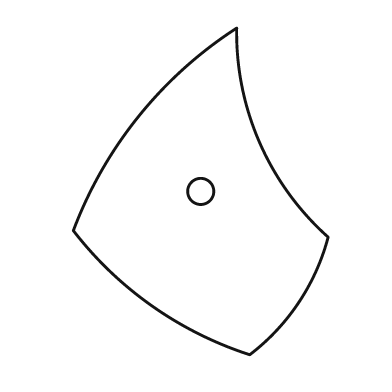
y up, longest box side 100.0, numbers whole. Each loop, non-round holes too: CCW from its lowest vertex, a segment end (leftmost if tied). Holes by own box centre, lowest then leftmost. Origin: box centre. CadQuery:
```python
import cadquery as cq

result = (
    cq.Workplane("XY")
    .moveTo(15.0, -50.0)
    .threePointArc((30.0, -34.0), (39.0, -14.0))
    .threePointArc((18.0, 15.0), (11.0, 50.0))
    .threePointArc((-19.0, 23.0), (-39.0, -12.0))
    .threePointArc((-15.0, -35.0), (15.0, -50.0))
    .close()
    .moveTo(0.0, 0.0)
    .circle(4.0)
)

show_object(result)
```